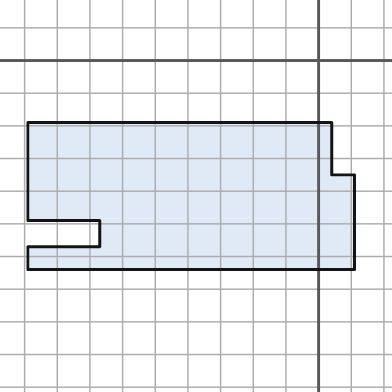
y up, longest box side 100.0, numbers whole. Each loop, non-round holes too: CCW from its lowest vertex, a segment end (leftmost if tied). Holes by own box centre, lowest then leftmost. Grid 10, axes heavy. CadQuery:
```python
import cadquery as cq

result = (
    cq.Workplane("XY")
    .moveTo(-89.0, -64.0)
    .lineTo(11.0, -64.0)
    .lineTo(11.0, -35.0)
    .lineTo(4.0, -35.0)
    .lineTo(4.0, -19.0)
    .lineTo(-89.0, -19.0)
    .lineTo(-89.0, -49.0)
    .lineTo(-67.0, -49.0)
    .lineTo(-67.0, -57.0)
    .lineTo(-89.0, -57.0)
    .close()
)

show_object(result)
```